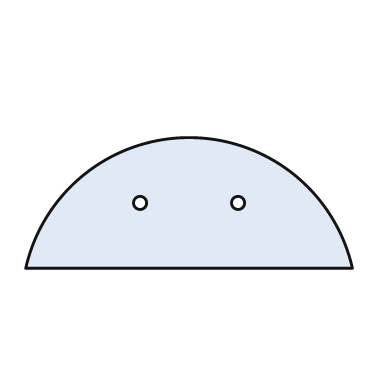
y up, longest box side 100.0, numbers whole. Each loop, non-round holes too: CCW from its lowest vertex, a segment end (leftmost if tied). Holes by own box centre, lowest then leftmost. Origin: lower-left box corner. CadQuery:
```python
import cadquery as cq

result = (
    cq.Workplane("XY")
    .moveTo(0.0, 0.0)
    .lineTo(100.0, 0.0)
    .threePointArc((50.0, 40.0), (0.0, 0.0))
    .close()
    .moveTo(35.0, 20.0)
    .circle(2.0)
    .moveTo(65.0, 20.0)
    .circle(2.0)
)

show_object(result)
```